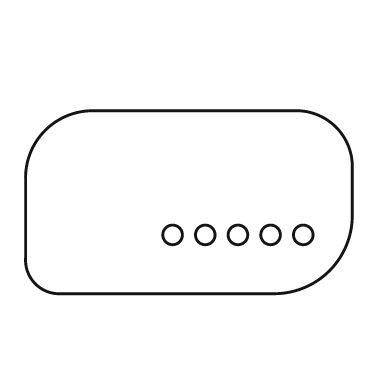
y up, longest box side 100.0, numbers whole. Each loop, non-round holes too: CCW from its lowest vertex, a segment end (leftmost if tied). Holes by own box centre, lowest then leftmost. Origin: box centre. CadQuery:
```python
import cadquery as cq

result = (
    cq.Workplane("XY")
    .moveTo(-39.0, -28.0)
    .lineTo(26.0, -28.0)
    .threePointArc((43.0, -21.0), (50.0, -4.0))
    .lineTo(50.0, 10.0)
    .threePointArc((45.0, 23.0), (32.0, 28.0))
    .lineTo(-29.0, 28.0)
    .threePointArc((-44.0, 22.0), (-50.0, 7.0))
    .lineTo(-50.0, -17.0)
    .threePointArc((-47.0, -25.0), (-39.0, -28.0))
    .close()
    .moveTo(-5.0, -10.0)
    .circle(3.0)
    .moveTo(5.0, -10.0)
    .circle(3.0)
    .moveTo(15.0, -10.0)
    .circle(3.0)
    .moveTo(25.0, -10.0)
    .circle(3.0)
    .moveTo(35.0, -10.0)
    .circle(3.0)
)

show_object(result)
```